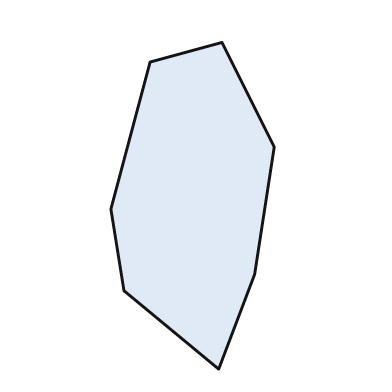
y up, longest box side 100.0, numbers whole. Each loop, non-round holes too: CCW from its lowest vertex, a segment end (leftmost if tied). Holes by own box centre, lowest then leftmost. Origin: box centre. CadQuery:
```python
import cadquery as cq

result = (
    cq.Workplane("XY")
    .moveTo(8.0, -50.0)
    .lineTo(19.0, -21.0)
    .lineTo(25.0, 18.0)
    .lineTo(9.0, 50.0)
    .lineTo(-13.0, 44.0)
    .lineTo(-25.0, -1.0)
    .lineTo(-21.0, -26.0)
    .close()
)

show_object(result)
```